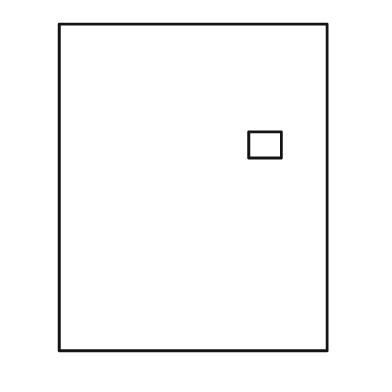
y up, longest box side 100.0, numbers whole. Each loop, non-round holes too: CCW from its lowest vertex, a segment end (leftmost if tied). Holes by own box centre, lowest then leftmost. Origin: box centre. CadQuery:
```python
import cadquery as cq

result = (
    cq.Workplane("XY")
    .moveTo(-41.0, -50.0)
    .lineTo(41.0, -50.0)
    .lineTo(41.0, 50.0)
    .lineTo(-41.0, 50.0)
    .close()
    .moveTo(17.0, 9.0)
    .lineTo(27.0, 9.0)
    .lineTo(27.0, 17.0)
    .lineTo(17.0, 17.0)
    .close()
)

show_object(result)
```